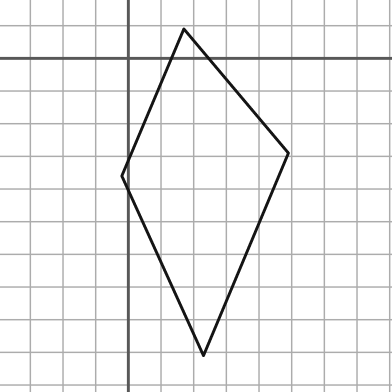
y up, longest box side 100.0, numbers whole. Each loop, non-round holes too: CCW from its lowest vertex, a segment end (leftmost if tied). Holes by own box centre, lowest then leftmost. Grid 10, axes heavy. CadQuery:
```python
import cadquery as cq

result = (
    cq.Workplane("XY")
    .moveTo(23.0, -91.0)
    .lineTo(49.0, -29.0)
    .lineTo(17.0, 9.0)
    .lineTo(-2.0, -36.0)
    .close()
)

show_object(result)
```